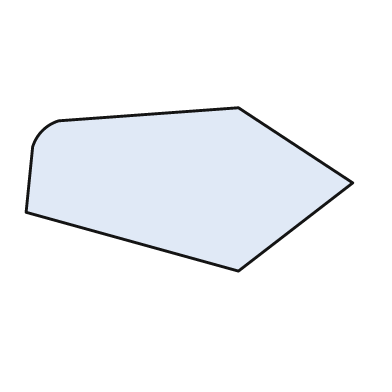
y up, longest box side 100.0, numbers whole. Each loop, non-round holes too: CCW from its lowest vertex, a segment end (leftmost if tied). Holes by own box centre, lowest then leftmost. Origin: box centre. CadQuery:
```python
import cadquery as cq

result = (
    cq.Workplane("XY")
    .moveTo(15.0, -25.0)
    .lineTo(50.0, 2.0)
    .lineTo(15.0, 25.0)
    .lineTo(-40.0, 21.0)
    .threePointArc((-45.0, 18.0), (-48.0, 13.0))
    .lineTo(-50.0, -7.0)
    .close()
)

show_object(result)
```